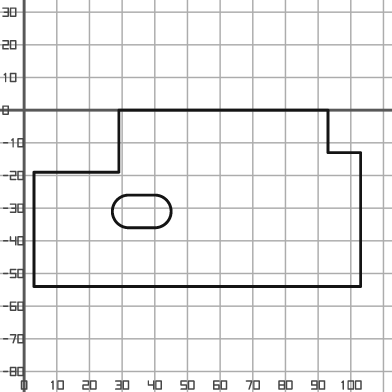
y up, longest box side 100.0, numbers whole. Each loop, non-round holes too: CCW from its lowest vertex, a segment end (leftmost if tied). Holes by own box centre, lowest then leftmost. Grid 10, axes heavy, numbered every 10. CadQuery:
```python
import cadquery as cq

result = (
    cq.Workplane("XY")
    .moveTo(3.0, -54.0)
    .lineTo(103.0, -54.0)
    .lineTo(103.0, -13.0)
    .lineTo(93.0, -13.0)
    .lineTo(93.0, 0.0)
    .lineTo(29.0, 0.0)
    .lineTo(29.0, -19.0)
    .lineTo(3.0, -19.0)
    .close()
    .moveTo(32.0, -36.0)
    .lineTo(40.0, -36.0)
    .threePointArc((45.0, -31.0), (40.0, -26.0))
    .lineTo(32.0, -26.0)
    .threePointArc((27.0, -31.0), (32.0, -36.0))
    .close()
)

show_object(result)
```